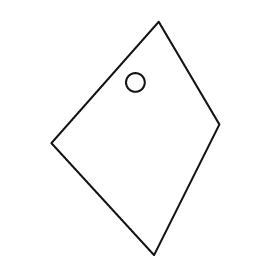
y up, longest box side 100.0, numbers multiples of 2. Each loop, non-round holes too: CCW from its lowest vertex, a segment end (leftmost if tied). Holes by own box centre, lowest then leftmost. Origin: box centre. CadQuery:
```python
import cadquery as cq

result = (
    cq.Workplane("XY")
    .moveTo(8.0, -50.0)
    .lineTo(36.0, 6.0)
    .lineTo(10.0, 50.0)
    .lineTo(-36.0, -2.0)
    .close()
    .moveTo(0.0, 24.0)
    .circle(4.0)
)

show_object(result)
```